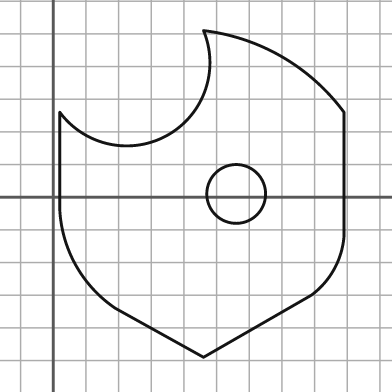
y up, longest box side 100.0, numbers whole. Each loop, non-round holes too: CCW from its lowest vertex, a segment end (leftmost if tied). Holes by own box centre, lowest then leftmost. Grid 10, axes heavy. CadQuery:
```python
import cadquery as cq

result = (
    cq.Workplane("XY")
    .moveTo(46.0, -49.0)
    .lineTo(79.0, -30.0)
    .threePointArc((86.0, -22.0), (89.0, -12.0))
    .lineTo(89.0, 26.0)
    .threePointArc((70.0, 43.0), (46.0, 51.0))
    .threePointArc((35.0, 19.0), (2.0, 26.0))
    .lineTo(2.0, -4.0)
    .threePointArc((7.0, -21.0), (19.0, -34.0))
    .close()
    .moveTo(56.0, 1.0)
    .circle(9.0)
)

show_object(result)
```